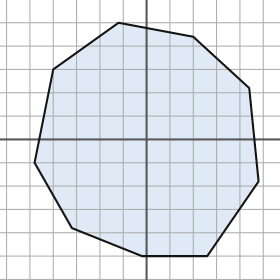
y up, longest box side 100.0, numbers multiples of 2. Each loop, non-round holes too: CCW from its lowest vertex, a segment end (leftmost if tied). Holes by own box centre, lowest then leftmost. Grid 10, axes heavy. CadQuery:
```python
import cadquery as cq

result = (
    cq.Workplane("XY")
    .moveTo(-2.0, -50.0)
    .lineTo(26.0, -50.0)
    .lineTo(48.0, -18.0)
    .lineTo(44.0, 22.0)
    .lineTo(20.0, 44.0)
    .lineTo(-12.0, 50.0)
    .lineTo(-40.0, 30.0)
    .lineTo(-48.0, -10.0)
    .lineTo(-32.0, -38.0)
    .close()
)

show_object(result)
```